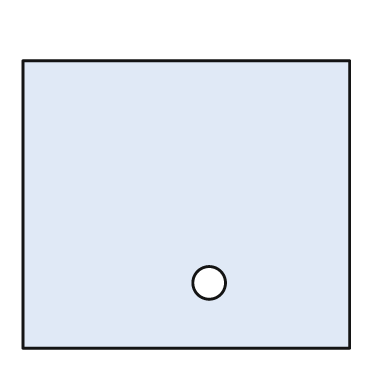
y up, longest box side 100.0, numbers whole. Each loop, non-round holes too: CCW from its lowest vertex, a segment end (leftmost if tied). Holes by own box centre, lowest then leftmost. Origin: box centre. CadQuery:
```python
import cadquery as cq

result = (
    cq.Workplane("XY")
    .moveTo(-50.0, -44.0)
    .lineTo(50.0, -44.0)
    .lineTo(50.0, 44.0)
    .lineTo(-50.0, 44.0)
    .close()
    .moveTo(7.0, -24.0)
    .circle(5.0)
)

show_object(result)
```